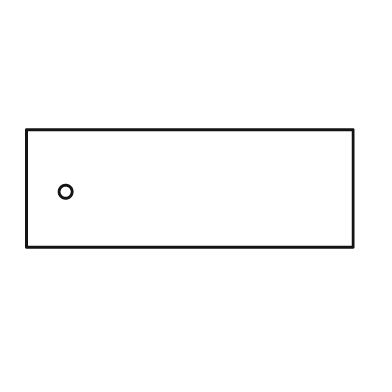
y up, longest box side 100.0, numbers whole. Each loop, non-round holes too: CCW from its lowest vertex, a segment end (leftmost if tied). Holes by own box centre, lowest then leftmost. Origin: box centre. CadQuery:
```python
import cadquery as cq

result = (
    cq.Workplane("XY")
    .moveTo(-50.0, -18.0)
    .lineTo(50.0, -18.0)
    .lineTo(50.0, 18.0)
    .lineTo(-50.0, 18.0)
    .close()
    .moveTo(-38.0, -1.0)
    .circle(2.0)
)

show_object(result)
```